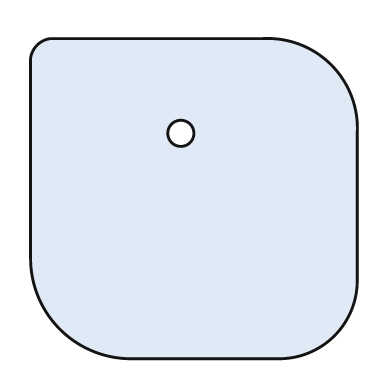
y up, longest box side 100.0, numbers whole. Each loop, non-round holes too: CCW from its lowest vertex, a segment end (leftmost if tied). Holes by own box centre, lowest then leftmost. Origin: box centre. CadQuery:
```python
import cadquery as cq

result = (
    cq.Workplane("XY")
    .moveTo(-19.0, -49.0)
    .lineTo(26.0, -49.0)
    .threePointArc((43.0, -42.0), (50.0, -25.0))
    .lineTo(50.0, 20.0)
    .threePointArc((42.0, 41.0), (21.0, 49.0))
    .lineTo(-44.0, 49.0)
    .threePointArc((-48.0, 47.0), (-50.0, 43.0))
    .lineTo(-50.0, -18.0)
    .threePointArc((-41.0, -40.0), (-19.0, -49.0))
    .close()
    .moveTo(-4.0, 20.0)
    .circle(4.0)
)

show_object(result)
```